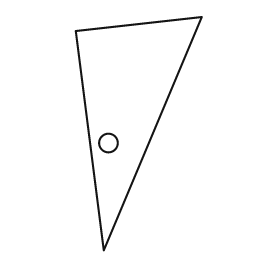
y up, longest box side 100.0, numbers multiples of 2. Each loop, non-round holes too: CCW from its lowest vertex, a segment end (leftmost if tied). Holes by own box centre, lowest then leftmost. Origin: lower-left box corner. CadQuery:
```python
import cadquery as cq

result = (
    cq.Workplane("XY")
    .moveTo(12.0, 0.0)
    .lineTo(54.0, 100.0)
    .lineTo(0.0, 94.0)
    .close()
    .moveTo(14.0, 46.0)
    .circle(4.0)
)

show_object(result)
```